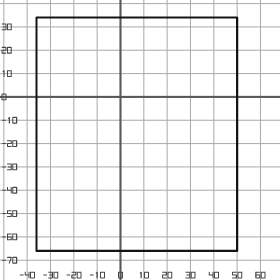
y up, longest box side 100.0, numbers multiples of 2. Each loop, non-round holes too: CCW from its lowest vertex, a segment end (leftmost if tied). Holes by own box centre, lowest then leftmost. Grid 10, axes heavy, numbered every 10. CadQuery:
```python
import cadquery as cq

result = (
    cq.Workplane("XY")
    .moveTo(-36.0, -66.0)
    .lineTo(50.0, -66.0)
    .lineTo(50.0, 34.0)
    .lineTo(-36.0, 34.0)
    .close()
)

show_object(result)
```